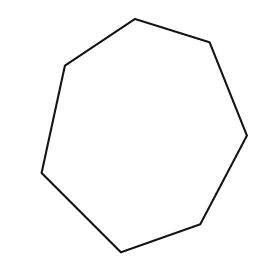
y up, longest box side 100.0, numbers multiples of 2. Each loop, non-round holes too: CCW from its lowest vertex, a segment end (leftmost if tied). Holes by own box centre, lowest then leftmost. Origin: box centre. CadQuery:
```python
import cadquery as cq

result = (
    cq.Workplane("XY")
    .moveTo(-10.0, -50.0)
    .lineTo(24.0, -38.0)
    .lineTo(44.0, 0.0)
    .lineTo(28.0, 40.0)
    .lineTo(-4.0, 50.0)
    .lineTo(-34.0, 30.0)
    .lineTo(-44.0, -16.0)
    .close()
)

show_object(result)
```